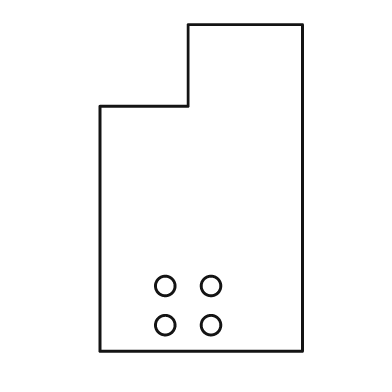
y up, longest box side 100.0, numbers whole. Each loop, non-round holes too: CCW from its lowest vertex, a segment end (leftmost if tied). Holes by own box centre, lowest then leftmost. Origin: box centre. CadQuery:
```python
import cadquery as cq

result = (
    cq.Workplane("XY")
    .moveTo(-31.0, -50.0)
    .lineTo(31.0, -50.0)
    .lineTo(31.0, 50.0)
    .lineTo(-4.0, 50.0)
    .lineTo(-4.0, 25.0)
    .lineTo(-31.0, 25.0)
    .close()
    .moveTo(-11.0, -42.0)
    .circle(3.0)
    .moveTo(3.0, -42.0)
    .circle(3.0)
    .moveTo(-11.0, -30.0)
    .circle(3.0)
    .moveTo(3.0, -30.0)
    .circle(3.0)
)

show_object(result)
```